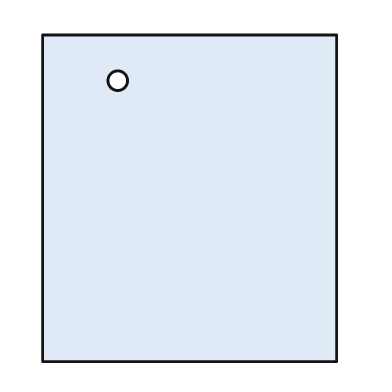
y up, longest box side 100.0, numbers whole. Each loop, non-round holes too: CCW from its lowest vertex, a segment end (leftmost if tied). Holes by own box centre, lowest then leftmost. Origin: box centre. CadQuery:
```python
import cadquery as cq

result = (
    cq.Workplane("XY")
    .moveTo(-45.0, -50.0)
    .lineTo(45.0, -50.0)
    .lineTo(45.0, 50.0)
    .lineTo(-45.0, 50.0)
    .close()
    .moveTo(-22.0, 36.0)
    .circle(3.0)
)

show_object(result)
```